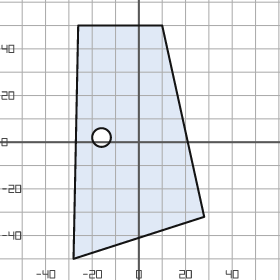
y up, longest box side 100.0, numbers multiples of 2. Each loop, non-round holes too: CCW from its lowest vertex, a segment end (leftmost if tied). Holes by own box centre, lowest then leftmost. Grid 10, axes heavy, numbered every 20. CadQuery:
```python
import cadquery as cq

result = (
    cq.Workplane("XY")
    .moveTo(-28.0, -50.0)
    .lineTo(28.0, -32.0)
    .lineTo(10.0, 50.0)
    .lineTo(-26.0, 50.0)
    .close()
    .moveTo(-16.0, 2.0)
    .circle(4.0)
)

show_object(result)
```